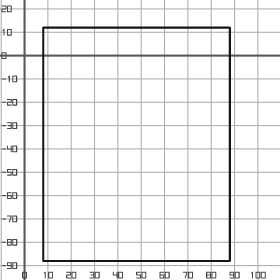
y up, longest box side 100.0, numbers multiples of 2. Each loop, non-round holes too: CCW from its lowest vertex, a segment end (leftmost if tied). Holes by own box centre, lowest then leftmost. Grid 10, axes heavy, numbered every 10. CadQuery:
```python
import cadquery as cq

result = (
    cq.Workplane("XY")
    .moveTo(8.0, -88.0)
    .lineTo(88.0, -88.0)
    .lineTo(88.0, 12.0)
    .lineTo(8.0, 12.0)
    .close()
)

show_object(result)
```